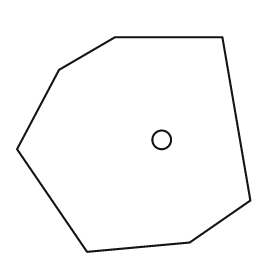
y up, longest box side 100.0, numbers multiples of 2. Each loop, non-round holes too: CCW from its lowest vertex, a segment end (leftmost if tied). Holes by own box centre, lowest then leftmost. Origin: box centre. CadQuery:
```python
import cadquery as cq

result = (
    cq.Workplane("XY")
    .moveTo(-20.0, -46.0)
    .lineTo(24.0, -42.0)
    .lineTo(50.0, -24.0)
    .lineTo(38.0, 46.0)
    .lineTo(-8.0, 46.0)
    .lineTo(-32.0, 32.0)
    .lineTo(-50.0, -2.0)
    .close()
    .moveTo(12.0, 2.0)
    .circle(4.0)
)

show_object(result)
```